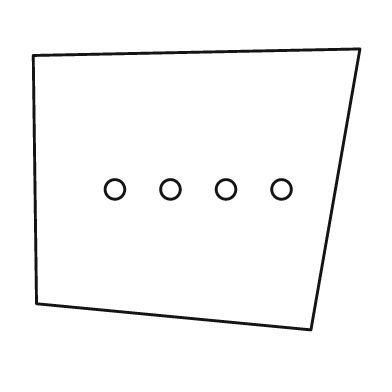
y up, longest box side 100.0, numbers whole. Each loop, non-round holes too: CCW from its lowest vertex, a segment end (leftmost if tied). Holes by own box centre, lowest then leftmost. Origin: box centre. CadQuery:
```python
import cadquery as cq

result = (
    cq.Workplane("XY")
    .moveTo(35.0, -43.0)
    .lineTo(50.0, 43.0)
    .lineTo(-50.0, 41.0)
    .lineTo(-49.0, -35.0)
    .close()
    .moveTo(-25.0, 0.0)
    .circle(3.0)
    .moveTo(-8.0, 0.0)
    .circle(3.0)
    .moveTo(9.0, 0.0)
    .circle(3.0)
    .moveTo(26.0, 0.0)
    .circle(3.0)
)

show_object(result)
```